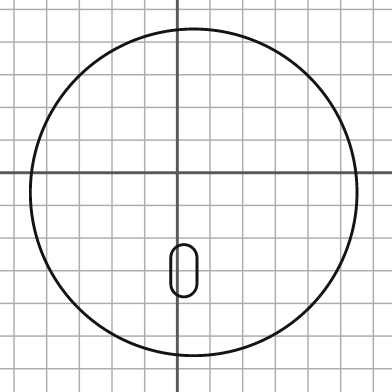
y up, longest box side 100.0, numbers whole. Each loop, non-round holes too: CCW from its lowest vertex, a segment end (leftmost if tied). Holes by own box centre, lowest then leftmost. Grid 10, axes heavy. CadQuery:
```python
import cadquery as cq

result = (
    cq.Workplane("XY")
    .moveTo(5.0, -6.0)
    .circle(50.0)
    .moveTo(-2.0, -34.0)
    .threePointArc((2.0, -38.0), (6.0, -34.0))
    .lineTo(6.0, -26.0)
    .threePointArc((2.0, -22.0), (-2.0, -26.0))
    .close()
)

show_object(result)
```